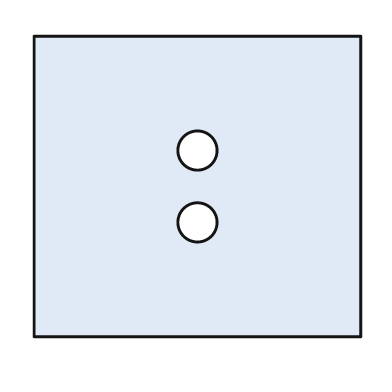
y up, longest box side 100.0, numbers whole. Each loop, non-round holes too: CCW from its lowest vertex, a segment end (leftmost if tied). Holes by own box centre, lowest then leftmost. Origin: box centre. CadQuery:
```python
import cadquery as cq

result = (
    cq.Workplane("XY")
    .moveTo(-50.0, -46.0)
    .lineTo(50.0, -46.0)
    .lineTo(50.0, 46.0)
    .lineTo(-50.0, 46.0)
    .close()
    .moveTo(0.0, -11.0)
    .circle(6.0)
    .moveTo(0.0, 11.0)
    .circle(6.0)
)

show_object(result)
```